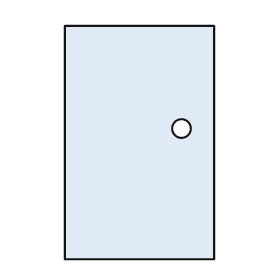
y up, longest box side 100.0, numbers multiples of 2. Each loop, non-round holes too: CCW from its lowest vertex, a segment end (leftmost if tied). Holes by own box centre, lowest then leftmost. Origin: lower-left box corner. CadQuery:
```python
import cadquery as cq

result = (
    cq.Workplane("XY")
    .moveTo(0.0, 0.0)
    .lineTo(64.0, 0.0)
    .lineTo(64.0, 100.0)
    .lineTo(0.0, 100.0)
    .close()
    .moveTo(50.0, 56.0)
    .circle(4.0)
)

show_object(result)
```